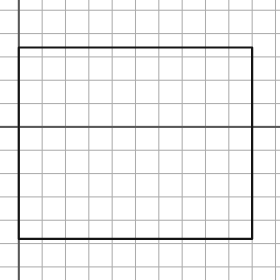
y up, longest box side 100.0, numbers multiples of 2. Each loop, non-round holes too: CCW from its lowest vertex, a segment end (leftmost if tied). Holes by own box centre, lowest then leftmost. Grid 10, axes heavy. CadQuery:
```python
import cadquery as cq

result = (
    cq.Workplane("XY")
    .moveTo(0.0, -48.0)
    .lineTo(100.0, -48.0)
    .lineTo(100.0, 34.0)
    .lineTo(0.0, 34.0)
    .close()
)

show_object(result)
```